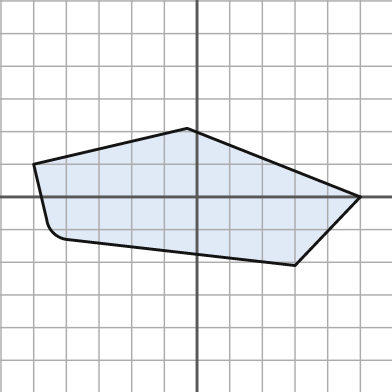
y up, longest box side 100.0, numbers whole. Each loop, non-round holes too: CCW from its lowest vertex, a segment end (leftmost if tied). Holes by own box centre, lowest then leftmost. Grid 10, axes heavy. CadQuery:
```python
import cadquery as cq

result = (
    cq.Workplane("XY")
    .moveTo(30.0, -21.0)
    .lineTo(50.0, 0.0)
    .lineTo(-3.0, 21.0)
    .lineTo(-50.0, 10.0)
    .lineTo(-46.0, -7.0)
    .threePointArc((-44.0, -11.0), (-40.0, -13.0))
    .close()
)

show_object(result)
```